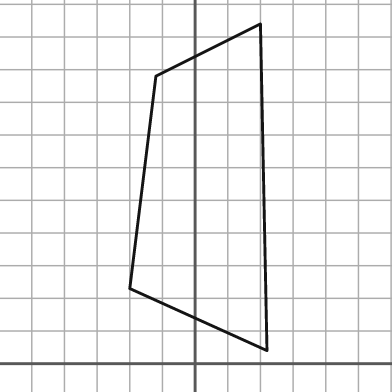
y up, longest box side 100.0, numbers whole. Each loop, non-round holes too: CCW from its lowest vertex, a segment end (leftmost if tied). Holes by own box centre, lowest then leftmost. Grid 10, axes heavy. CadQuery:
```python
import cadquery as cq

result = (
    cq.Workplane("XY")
    .moveTo(22.0, 4.0)
    .lineTo(20.0, 104.0)
    .lineTo(-12.0, 88.0)
    .lineTo(-20.0, 23.0)
    .close()
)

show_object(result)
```